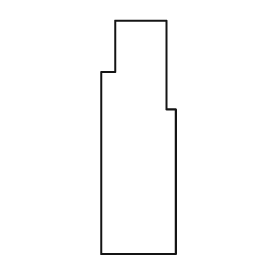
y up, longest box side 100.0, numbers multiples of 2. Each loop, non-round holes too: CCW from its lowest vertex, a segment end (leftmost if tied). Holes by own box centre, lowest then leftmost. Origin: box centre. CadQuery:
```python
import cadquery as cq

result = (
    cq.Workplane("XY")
    .moveTo(-16.0, -50.0)
    .lineTo(16.0, -50.0)
    .lineTo(16.0, 12.0)
    .lineTo(12.0, 12.0)
    .lineTo(12.0, 50.0)
    .lineTo(-10.0, 50.0)
    .lineTo(-10.0, 28.0)
    .lineTo(-16.0, 28.0)
    .close()
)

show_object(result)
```